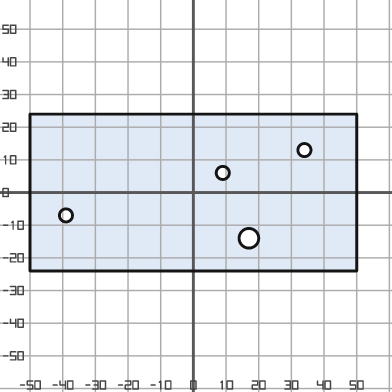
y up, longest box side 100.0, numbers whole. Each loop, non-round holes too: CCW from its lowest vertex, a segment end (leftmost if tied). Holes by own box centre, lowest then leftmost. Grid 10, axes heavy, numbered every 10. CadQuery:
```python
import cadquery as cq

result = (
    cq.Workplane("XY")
    .moveTo(-50.0, -24.0)
    .lineTo(50.0, -24.0)
    .lineTo(50.0, 24.0)
    .lineTo(-50.0, 24.0)
    .close()
    .moveTo(17.0, -14.0)
    .circle(3.0)
    .moveTo(-39.0, -7.0)
    .circle(2.0)
    .moveTo(9.0, 6.0)
    .circle(2.0)
    .moveTo(34.0, 13.0)
    .circle(2.0)
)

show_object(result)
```